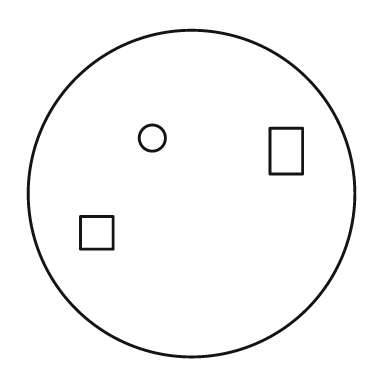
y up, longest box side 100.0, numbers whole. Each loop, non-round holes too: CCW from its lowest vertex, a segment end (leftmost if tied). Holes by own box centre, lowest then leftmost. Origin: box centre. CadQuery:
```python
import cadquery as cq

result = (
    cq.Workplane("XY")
    .moveTo(0.0, 0.0)
    .circle(50.0)
    .moveTo(-34.0, -17.0)
    .lineTo(-24.0, -17.0)
    .lineTo(-24.0, -7.0)
    .lineTo(-34.0, -7.0)
    .close()
    .moveTo(24.0, 6.0)
    .lineTo(34.0, 6.0)
    .lineTo(34.0, 20.0)
    .lineTo(24.0, 20.0)
    .close()
    .moveTo(-12.0, 17.0)
    .circle(4.0)
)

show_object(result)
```